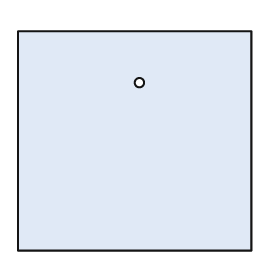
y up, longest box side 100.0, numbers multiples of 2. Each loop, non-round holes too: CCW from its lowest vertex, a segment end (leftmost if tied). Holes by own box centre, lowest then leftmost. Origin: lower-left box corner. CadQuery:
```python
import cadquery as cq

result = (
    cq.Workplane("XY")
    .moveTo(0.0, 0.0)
    .lineTo(100.0, 0.0)
    .lineTo(100.0, 94.0)
    .lineTo(0.0, 94.0)
    .close()
    .moveTo(52.0, 72.0)
    .circle(2.0)
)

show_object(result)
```